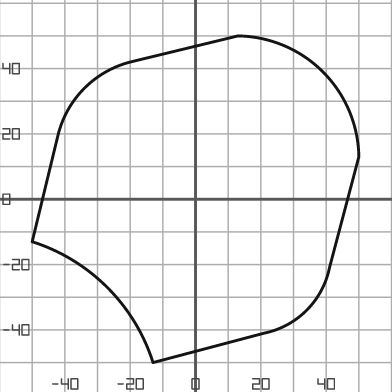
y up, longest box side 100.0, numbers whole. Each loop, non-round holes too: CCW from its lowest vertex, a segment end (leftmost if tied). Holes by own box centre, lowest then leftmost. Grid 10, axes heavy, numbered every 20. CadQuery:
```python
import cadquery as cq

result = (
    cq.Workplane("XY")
    .moveTo(-13.0, -50.0)
    .lineTo(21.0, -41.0)
    .threePointArc((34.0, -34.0), (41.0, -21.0))
    .lineTo(50.0, 13.0)
    .threePointArc((39.0, 39.0), (13.0, 50.0))
    .lineTo(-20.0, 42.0)
    .threePointArc((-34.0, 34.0), (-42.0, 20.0))
    .lineTo(-50.0, -13.0)
    .threePointArc((-27.0, -27.0), (-13.0, -50.0))
    .close()
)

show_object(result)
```